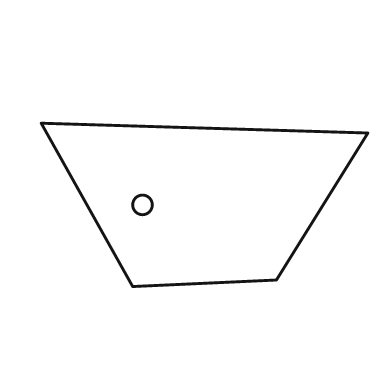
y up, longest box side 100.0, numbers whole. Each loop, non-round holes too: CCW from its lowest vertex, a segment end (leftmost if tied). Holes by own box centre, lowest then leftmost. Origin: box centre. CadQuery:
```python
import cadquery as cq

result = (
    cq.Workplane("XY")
    .moveTo(-22.0, -25.0)
    .lineTo(22.0, -23.0)
    .lineTo(50.0, 22.0)
    .lineTo(-50.0, 25.0)
    .close()
    .moveTo(-19.0, 0.0)
    .circle(3.0)
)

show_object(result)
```